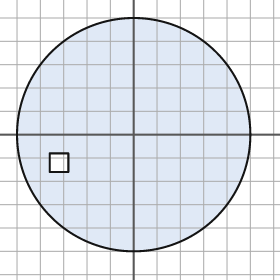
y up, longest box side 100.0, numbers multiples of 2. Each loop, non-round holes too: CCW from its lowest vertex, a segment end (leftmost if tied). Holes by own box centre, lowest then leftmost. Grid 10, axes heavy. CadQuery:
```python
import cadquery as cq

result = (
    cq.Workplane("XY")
    .moveTo(0.0, 0.0)
    .circle(50.0)
    .moveTo(-36.0, -16.0)
    .lineTo(-28.0, -16.0)
    .lineTo(-28.0, -8.0)
    .lineTo(-36.0, -8.0)
    .close()
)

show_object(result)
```